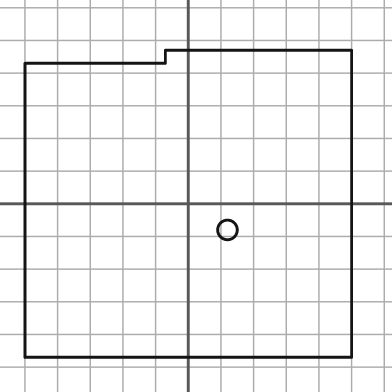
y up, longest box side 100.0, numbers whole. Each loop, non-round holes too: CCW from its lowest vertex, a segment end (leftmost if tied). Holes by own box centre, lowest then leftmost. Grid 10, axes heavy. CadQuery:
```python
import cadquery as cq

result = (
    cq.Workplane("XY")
    .moveTo(-50.0, -47.0)
    .lineTo(50.0, -47.0)
    .lineTo(50.0, 47.0)
    .lineTo(-7.0, 47.0)
    .lineTo(-7.0, 43.0)
    .lineTo(-50.0, 43.0)
    .close()
    .moveTo(12.0, -8.0)
    .circle(3.0)
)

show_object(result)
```